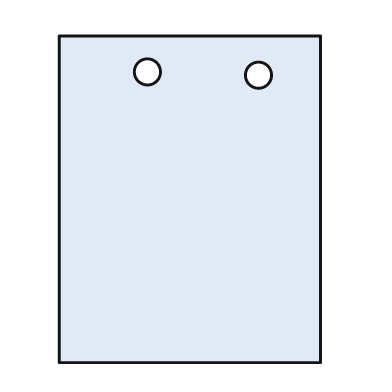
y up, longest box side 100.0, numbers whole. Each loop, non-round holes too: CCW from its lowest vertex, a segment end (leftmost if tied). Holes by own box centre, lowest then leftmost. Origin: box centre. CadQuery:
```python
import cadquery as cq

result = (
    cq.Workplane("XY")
    .moveTo(-40.0, -50.0)
    .lineTo(40.0, -50.0)
    .lineTo(40.0, 50.0)
    .lineTo(-40.0, 50.0)
    .close()
    .moveTo(21.0, 38.0)
    .circle(4.0)
    .moveTo(-13.0, 39.0)
    .circle(4.0)
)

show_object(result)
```